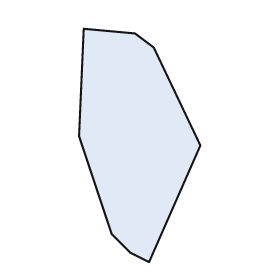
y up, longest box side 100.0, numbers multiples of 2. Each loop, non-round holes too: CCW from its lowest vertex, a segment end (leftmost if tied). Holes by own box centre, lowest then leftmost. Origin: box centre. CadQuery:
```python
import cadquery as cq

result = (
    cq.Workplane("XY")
    .moveTo(4.0, -50.0)
    .lineTo(26.0, 0.0)
    .lineTo(6.0, 42.0)
    .lineTo(-2.0, 48.0)
    .lineTo(-24.0, 50.0)
    .lineTo(-26.0, 4.0)
    .lineTo(-12.0, -38.0)
    .lineTo(-4.0, -46.0)
    .close()
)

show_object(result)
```